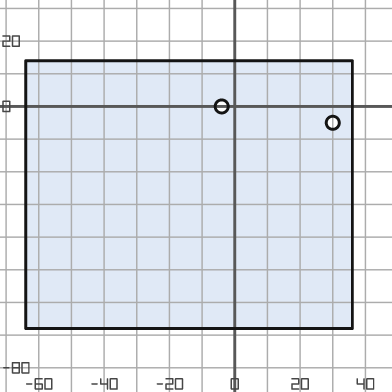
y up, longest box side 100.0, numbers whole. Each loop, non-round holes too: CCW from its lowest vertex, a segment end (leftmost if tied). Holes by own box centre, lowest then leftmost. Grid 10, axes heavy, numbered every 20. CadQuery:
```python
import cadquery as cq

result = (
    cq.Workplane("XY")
    .moveTo(-64.0, -68.0)
    .lineTo(36.0, -68.0)
    .lineTo(36.0, 14.0)
    .lineTo(-64.0, 14.0)
    .close()
    .moveTo(30.0, -5.0)
    .circle(2.0)
    .moveTo(-4.0, 0.0)
    .circle(2.0)
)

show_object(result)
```